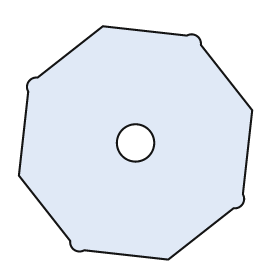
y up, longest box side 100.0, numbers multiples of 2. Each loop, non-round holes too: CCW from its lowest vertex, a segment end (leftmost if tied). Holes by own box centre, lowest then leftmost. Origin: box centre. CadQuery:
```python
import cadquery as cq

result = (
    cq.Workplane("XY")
    .moveTo(14.0, -50.0)
    .lineTo(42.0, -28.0)
    .threePointArc((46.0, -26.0), (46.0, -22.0))
    .lineTo(50.0, 14.0)
    .lineTo(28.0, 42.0)
    .threePointArc((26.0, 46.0), (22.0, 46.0))
    .lineTo(-14.0, 50.0)
    .lineTo(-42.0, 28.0)
    .threePointArc((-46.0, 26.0), (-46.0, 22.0))
    .lineTo(-50.0, -14.0)
    .lineTo(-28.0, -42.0)
    .threePointArc((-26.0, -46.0), (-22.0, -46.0))
    .close()
    .moveTo(0.0, 0.0)
    .circle(8.0)
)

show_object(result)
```